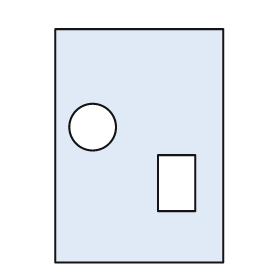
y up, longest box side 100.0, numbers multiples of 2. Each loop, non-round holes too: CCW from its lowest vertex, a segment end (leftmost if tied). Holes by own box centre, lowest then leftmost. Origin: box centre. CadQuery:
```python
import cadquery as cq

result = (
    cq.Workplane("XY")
    .moveTo(-36.0, -50.0)
    .lineTo(36.0, -50.0)
    .lineTo(36.0, 50.0)
    .lineTo(-36.0, 50.0)
    .close()
    .moveTo(8.0, -28.0)
    .lineTo(24.0, -28.0)
    .lineTo(24.0, -4.0)
    .lineTo(8.0, -4.0)
    .close()
    .moveTo(-20.0, 8.0)
    .circle(10.0)
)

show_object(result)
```